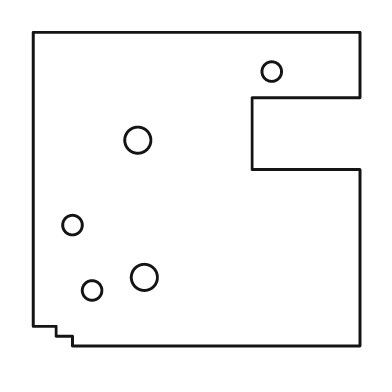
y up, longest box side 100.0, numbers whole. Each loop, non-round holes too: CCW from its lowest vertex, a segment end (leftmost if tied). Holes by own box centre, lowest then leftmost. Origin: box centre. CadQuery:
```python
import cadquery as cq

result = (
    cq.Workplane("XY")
    .moveTo(-38.0, -48.0)
    .lineTo(50.0, -48.0)
    .lineTo(50.0, 6.0)
    .lineTo(17.0, 6.0)
    .lineTo(17.0, 28.0)
    .lineTo(50.0, 28.0)
    .lineTo(50.0, 48.0)
    .lineTo(-50.0, 48.0)
    .lineTo(-50.0, -42.0)
    .lineTo(-43.0, -42.0)
    .lineTo(-43.0, -45.0)
    .lineTo(-38.0, -45.0)
    .close()
    .moveTo(-32.0, -31.0)
    .circle(3.0)
    .moveTo(-16.0, -27.0)
    .circle(4.0)
    .moveTo(-38.0, -11.0)
    .circle(3.0)
    .moveTo(-18.0, 15.0)
    .circle(4.0)
    .moveTo(23.0, 36.0)
    .circle(3.0)
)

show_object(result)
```